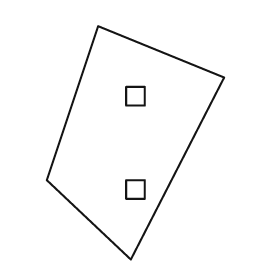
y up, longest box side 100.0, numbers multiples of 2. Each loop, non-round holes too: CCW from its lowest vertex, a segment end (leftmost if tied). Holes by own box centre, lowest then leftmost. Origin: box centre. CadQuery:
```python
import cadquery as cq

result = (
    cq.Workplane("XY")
    .moveTo(-2.0, -50.0)
    .lineTo(38.0, 28.0)
    .lineTo(-16.0, 50.0)
    .lineTo(-38.0, -16.0)
    .close()
    .moveTo(-4.0, -24.0)
    .lineTo(4.0, -24.0)
    .lineTo(4.0, -16.0)
    .lineTo(-4.0, -16.0)
    .close()
    .moveTo(-4.0, 16.0)
    .lineTo(4.0, 16.0)
    .lineTo(4.0, 24.0)
    .lineTo(-4.0, 24.0)
    .close()
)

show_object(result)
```